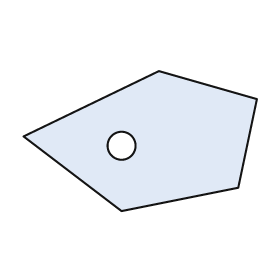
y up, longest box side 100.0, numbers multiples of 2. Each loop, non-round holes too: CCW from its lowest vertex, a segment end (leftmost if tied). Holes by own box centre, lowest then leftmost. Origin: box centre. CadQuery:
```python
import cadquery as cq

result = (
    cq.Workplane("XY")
    .moveTo(-8.0, -30.0)
    .lineTo(42.0, -20.0)
    .lineTo(50.0, 18.0)
    .lineTo(8.0, 30.0)
    .lineTo(-50.0, 2.0)
    .close()
    .moveTo(-8.0, -2.0)
    .circle(6.0)
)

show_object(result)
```